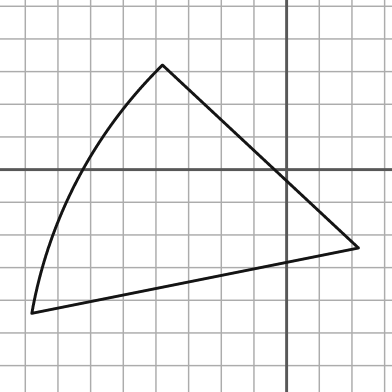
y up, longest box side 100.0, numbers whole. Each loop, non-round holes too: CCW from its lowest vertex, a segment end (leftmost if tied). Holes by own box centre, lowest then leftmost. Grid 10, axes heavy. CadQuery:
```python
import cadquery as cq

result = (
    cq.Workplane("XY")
    .moveTo(-78.0, -44.0)
    .lineTo(22.0, -24.0)
    .lineTo(-38.0, 32.0)
    .threePointArc((-64.0, -3.0), (-78.0, -44.0))
    .close()
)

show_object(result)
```